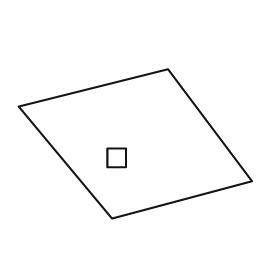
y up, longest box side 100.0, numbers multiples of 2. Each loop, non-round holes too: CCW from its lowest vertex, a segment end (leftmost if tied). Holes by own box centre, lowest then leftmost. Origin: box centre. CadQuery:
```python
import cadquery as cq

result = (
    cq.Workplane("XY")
    .moveTo(-10.0, -32.0)
    .lineTo(50.0, -16.0)
    .lineTo(14.0, 32.0)
    .lineTo(-50.0, 16.0)
    .close()
    .moveTo(-12.0, -10.0)
    .lineTo(-4.0, -10.0)
    .lineTo(-4.0, -2.0)
    .lineTo(-12.0, -2.0)
    .close()
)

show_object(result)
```